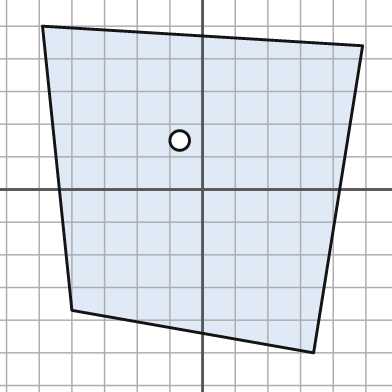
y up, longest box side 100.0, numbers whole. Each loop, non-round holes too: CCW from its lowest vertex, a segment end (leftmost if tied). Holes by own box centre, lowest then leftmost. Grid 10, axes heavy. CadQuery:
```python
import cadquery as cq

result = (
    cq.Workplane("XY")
    .moveTo(34.0, -50.0)
    .lineTo(49.0, 44.0)
    .lineTo(-49.0, 50.0)
    .lineTo(-40.0, -37.0)
    .close()
    .moveTo(-7.0, 15.0)
    .circle(3.0)
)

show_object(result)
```